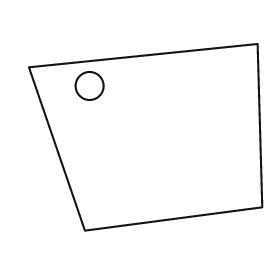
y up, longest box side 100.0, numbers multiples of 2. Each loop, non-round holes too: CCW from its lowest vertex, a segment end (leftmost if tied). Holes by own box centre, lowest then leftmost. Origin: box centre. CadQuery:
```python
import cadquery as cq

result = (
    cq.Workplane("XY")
    .moveTo(-26.0, -40.0)
    .lineTo(50.0, -30.0)
    .lineTo(48.0, 40.0)
    .lineTo(-50.0, 30.0)
    .close()
    .moveTo(-24.0, 22.0)
    .circle(6.0)
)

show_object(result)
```